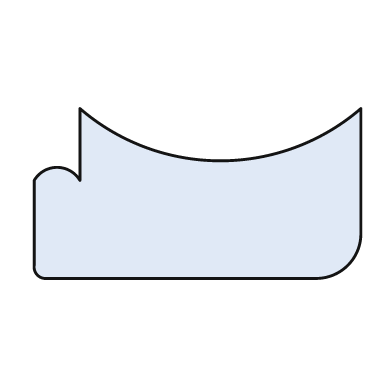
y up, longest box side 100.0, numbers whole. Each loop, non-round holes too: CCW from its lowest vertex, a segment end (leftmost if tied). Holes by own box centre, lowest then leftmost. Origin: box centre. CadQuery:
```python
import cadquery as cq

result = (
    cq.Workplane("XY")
    .moveTo(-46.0, -26.0)
    .lineTo(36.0, -26.0)
    .threePointArc((46.0, -22.0), (50.0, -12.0))
    .lineTo(50.0, 26.0)
    .threePointArc((7.0, 10.0), (-36.0, 26.0))
    .lineTo(-36.0, 4.0)
    .threePointArc((-43.0, 8.0), (-50.0, 4.0))
    .lineTo(-50.0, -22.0)
    .threePointArc((-49.0, -25.0), (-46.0, -26.0))
    .close()
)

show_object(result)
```